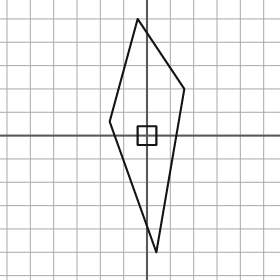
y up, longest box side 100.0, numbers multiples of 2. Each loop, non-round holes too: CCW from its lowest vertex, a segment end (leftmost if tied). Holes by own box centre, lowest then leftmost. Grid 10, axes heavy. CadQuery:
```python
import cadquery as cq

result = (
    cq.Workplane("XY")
    .moveTo(4.0, -50.0)
    .lineTo(16.0, 20.0)
    .lineTo(-4.0, 50.0)
    .lineTo(-16.0, 6.0)
    .close()
    .moveTo(-4.0, -4.0)
    .lineTo(4.0, -4.0)
    .lineTo(4.0, 4.0)
    .lineTo(-4.0, 4.0)
    .close()
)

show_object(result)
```